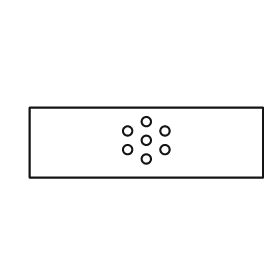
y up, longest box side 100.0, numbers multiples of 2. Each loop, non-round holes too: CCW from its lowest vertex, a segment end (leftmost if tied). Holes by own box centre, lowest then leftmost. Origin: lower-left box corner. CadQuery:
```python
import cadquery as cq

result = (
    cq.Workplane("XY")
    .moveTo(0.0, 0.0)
    .lineTo(100.0, 0.0)
    .lineTo(100.0, 30.0)
    .lineTo(0.0, 30.0)
    .close()
    .moveTo(50.0, 8.0)
    .circle(2.0)
    .moveTo(42.0, 12.0)
    .circle(2.0)
    .moveTo(58.0, 12.0)
    .circle(2.0)
    .moveTo(50.0, 16.0)
    .circle(2.0)
    .moveTo(42.0, 20.0)
    .circle(2.0)
    .moveTo(58.0, 20.0)
    .circle(2.0)
    .moveTo(50.0, 24.0)
    .circle(2.0)
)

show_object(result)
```